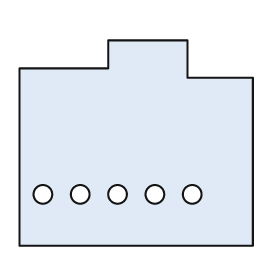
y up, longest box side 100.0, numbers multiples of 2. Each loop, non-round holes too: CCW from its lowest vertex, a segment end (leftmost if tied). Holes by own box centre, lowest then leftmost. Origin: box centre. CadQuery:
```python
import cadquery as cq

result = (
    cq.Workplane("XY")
    .moveTo(-50.0, -44.0)
    .lineTo(50.0, -44.0)
    .lineTo(50.0, 28.0)
    .lineTo(22.0, 28.0)
    .lineTo(22.0, 44.0)
    .lineTo(-12.0, 44.0)
    .lineTo(-12.0, 32.0)
    .lineTo(-50.0, 32.0)
    .close()
    .moveTo(-40.0, -22.0)
    .circle(4.0)
    .moveTo(-24.0, -22.0)
    .circle(4.0)
    .moveTo(-8.0, -22.0)
    .circle(4.0)
    .moveTo(8.0, -22.0)
    .circle(4.0)
    .moveTo(24.0, -22.0)
    .circle(4.0)
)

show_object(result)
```